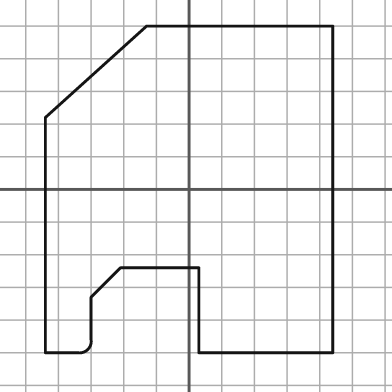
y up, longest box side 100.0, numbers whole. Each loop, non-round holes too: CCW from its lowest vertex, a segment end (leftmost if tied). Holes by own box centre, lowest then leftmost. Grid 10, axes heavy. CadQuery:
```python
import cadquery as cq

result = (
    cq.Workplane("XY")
    .moveTo(-44.0, -50.0)
    .lineTo(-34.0, -50.0)
    .threePointArc((-31.0, -49.0), (-30.0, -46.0))
    .lineTo(-30.0, -33.0)
    .lineTo(-21.0, -24.0)
    .lineTo(3.0, -24.0)
    .lineTo(3.0, -50.0)
    .lineTo(44.0, -50.0)
    .lineTo(44.0, 50.0)
    .lineTo(-13.0, 50.0)
    .lineTo(-44.0, 22.0)
    .close()
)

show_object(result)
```